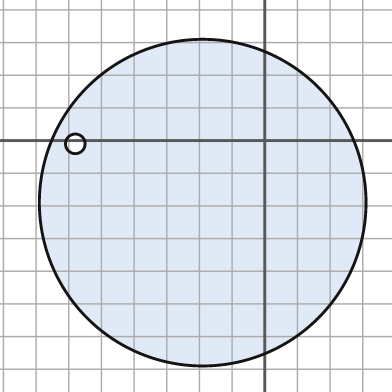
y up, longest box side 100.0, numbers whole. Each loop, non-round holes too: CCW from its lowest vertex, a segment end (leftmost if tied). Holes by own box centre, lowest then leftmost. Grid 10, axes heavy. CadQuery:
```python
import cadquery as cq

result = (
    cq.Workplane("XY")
    .moveTo(-19.0, -19.0)
    .circle(50.0)
    .moveTo(-58.0, -1.0)
    .circle(3.0)
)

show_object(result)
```